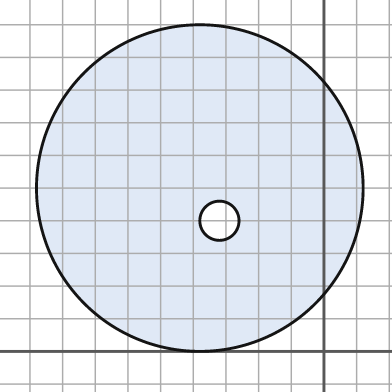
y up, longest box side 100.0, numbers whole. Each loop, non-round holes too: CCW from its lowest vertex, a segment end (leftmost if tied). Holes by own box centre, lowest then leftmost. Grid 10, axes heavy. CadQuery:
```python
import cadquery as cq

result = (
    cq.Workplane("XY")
    .moveTo(-38.0, 50.0)
    .circle(50.0)
    .moveTo(-32.0, 40.0)
    .circle(6.0)
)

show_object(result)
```